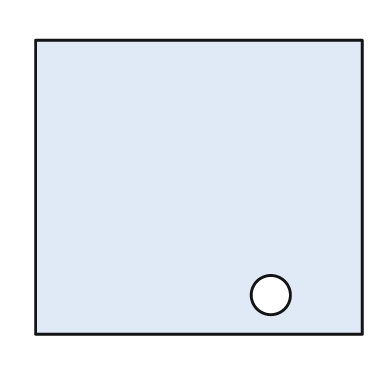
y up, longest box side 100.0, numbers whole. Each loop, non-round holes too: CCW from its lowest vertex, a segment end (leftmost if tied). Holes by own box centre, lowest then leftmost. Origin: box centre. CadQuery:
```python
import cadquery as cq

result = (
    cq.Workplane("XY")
    .moveTo(-50.0, -45.0)
    .lineTo(50.0, -45.0)
    .lineTo(50.0, 45.0)
    .lineTo(-50.0, 45.0)
    .close()
    .moveTo(22.0, -33.0)
    .circle(6.0)
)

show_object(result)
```